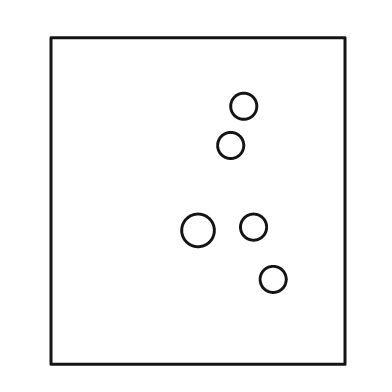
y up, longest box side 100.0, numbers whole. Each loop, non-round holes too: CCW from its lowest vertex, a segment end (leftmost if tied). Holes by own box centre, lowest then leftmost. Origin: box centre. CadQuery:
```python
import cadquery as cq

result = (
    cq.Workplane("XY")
    .moveTo(-45.0, -50.0)
    .lineTo(45.0, -50.0)
    .lineTo(45.0, 50.0)
    .lineTo(-45.0, 50.0)
    .close()
    .moveTo(23.0, -24.0)
    .circle(4.0)
    .moveTo(0.0, -9.0)
    .circle(5.0)
    .moveTo(17.0, -8.0)
    .circle(4.0)
    .moveTo(10.0, 17.0)
    .circle(4.0)
    .moveTo(14.0, 29.0)
    .circle(4.0)
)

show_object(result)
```